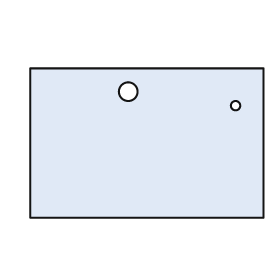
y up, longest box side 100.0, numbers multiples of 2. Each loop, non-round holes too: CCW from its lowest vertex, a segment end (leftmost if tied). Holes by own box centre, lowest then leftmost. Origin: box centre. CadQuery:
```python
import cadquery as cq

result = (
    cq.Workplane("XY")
    .moveTo(-50.0, -32.0)
    .lineTo(50.0, -32.0)
    .lineTo(50.0, 32.0)
    .lineTo(-50.0, 32.0)
    .close()
    .moveTo(38.0, 16.0)
    .circle(2.0)
    .moveTo(-8.0, 22.0)
    .circle(4.0)
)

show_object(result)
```